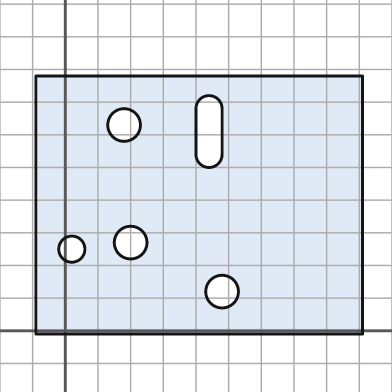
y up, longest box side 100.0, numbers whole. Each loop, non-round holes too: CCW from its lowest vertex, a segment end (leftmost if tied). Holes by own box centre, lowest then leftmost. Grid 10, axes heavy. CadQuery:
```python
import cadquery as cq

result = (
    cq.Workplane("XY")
    .moveTo(-9.0, -1.0)
    .lineTo(91.0, -1.0)
    .lineTo(91.0, 78.0)
    .lineTo(-9.0, 78.0)
    .close()
    .moveTo(48.0, 12.0)
    .circle(5.0)
    .moveTo(2.0, 25.0)
    .circle(4.0)
    .moveTo(20.0, 27.0)
    .circle(5.0)
    .moveTo(40.0, 54.0)
    .threePointArc((44.0, 50.0), (48.0, 54.0))
    .lineTo(48.0, 68.0)
    .threePointArc((44.0, 72.0), (40.0, 68.0))
    .close()
    .moveTo(18.0, 63.0)
    .circle(5.0)
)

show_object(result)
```